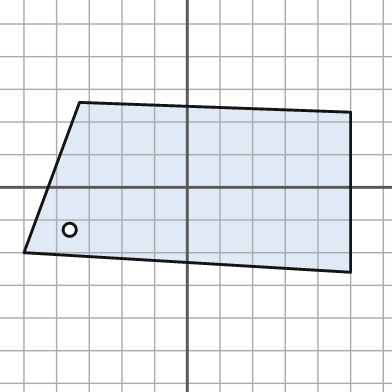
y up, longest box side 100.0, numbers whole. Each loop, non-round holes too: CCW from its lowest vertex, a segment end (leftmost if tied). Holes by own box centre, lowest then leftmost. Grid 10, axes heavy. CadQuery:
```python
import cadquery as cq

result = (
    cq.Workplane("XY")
    .moveTo(50.0, -26.0)
    .lineTo(50.0, 23.0)
    .lineTo(-33.0, 26.0)
    .lineTo(-50.0, -20.0)
    .close()
    .moveTo(-36.0, -13.0)
    .circle(2.0)
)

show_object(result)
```